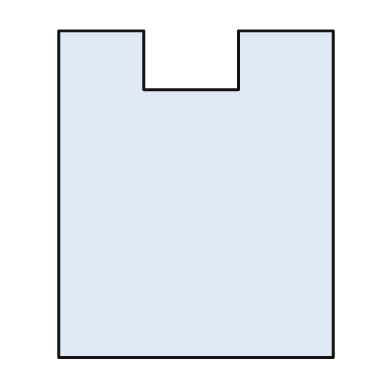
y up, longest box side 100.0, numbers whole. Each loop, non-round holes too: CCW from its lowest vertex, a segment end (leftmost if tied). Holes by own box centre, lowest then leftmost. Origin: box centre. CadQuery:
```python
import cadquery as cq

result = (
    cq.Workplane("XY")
    .moveTo(-42.0, -50.0)
    .lineTo(42.0, -50.0)
    .lineTo(42.0, 50.0)
    .lineTo(13.0, 50.0)
    .lineTo(13.0, 32.0)
    .lineTo(-16.0, 32.0)
    .lineTo(-16.0, 50.0)
    .lineTo(-42.0, 50.0)
    .close()
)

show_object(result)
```